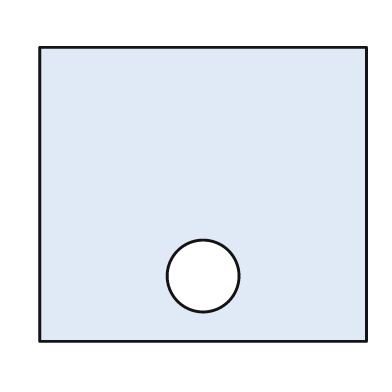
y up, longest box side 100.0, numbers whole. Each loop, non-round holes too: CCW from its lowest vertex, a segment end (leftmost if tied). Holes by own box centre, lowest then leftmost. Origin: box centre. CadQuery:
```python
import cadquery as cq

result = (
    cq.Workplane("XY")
    .moveTo(-50.0, -45.0)
    .lineTo(50.0, -45.0)
    .lineTo(50.0, 45.0)
    .lineTo(-50.0, 45.0)
    .close()
    .moveTo(0.0, -25.0)
    .circle(11.0)
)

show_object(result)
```